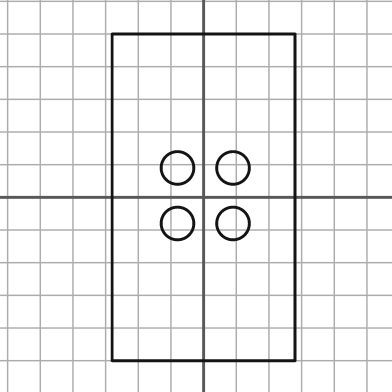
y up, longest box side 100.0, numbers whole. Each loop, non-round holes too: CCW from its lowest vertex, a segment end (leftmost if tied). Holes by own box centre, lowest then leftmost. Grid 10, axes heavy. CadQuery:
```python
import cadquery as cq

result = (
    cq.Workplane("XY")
    .moveTo(-28.0, -50.0)
    .lineTo(28.0, -50.0)
    .lineTo(28.0, 50.0)
    .lineTo(-28.0, 50.0)
    .close()
    .moveTo(-8.0, -8.0)
    .circle(5.0)
    .moveTo(9.0, -8.0)
    .circle(5.0)
    .moveTo(-8.0, 9.0)
    .circle(5.0)
    .moveTo(9.0, 9.0)
    .circle(5.0)
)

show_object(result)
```